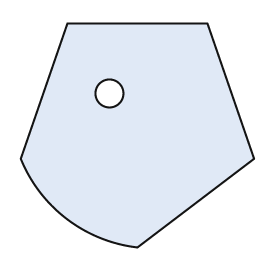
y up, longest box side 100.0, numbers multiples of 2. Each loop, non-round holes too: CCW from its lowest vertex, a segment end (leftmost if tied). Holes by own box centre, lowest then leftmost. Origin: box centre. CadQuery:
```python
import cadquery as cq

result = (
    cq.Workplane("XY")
    .moveTo(0.0, -48.0)
    .lineTo(50.0, -10.0)
    .lineTo(30.0, 48.0)
    .lineTo(-30.0, 48.0)
    .lineTo(-50.0, -10.0)
    .threePointArc((-30.0, -36.0), (0.0, -48.0))
    .close()
    .moveTo(-12.0, 18.0)
    .circle(6.0)
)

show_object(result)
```